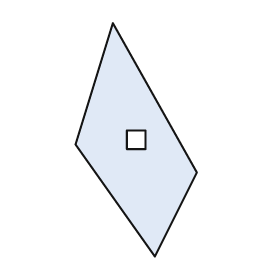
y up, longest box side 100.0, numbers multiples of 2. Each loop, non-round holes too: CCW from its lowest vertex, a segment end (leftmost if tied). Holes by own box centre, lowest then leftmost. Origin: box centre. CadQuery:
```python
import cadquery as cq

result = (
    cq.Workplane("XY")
    .moveTo(8.0, -50.0)
    .lineTo(26.0, -14.0)
    .lineTo(-10.0, 50.0)
    .lineTo(-26.0, -2.0)
    .close()
    .moveTo(-4.0, -4.0)
    .lineTo(4.0, -4.0)
    .lineTo(4.0, 4.0)
    .lineTo(-4.0, 4.0)
    .close()
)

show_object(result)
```